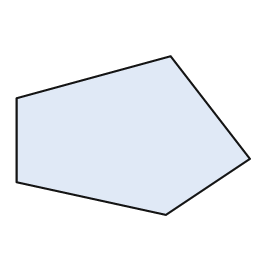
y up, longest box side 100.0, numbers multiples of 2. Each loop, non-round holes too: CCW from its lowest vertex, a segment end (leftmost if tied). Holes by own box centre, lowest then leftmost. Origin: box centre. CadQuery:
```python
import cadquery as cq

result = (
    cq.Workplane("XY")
    .moveTo(14.0, -34.0)
    .lineTo(50.0, -10.0)
    .lineTo(16.0, 34.0)
    .lineTo(-50.0, 16.0)
    .lineTo(-50.0, -20.0)
    .close()
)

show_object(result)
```